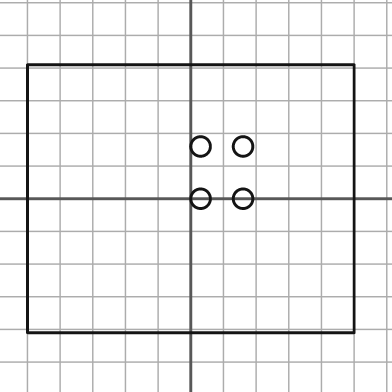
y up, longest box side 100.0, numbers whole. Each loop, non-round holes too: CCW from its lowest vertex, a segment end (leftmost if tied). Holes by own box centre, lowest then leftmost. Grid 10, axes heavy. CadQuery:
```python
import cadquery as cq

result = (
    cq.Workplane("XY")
    .moveTo(-50.0, -41.0)
    .lineTo(50.0, -41.0)
    .lineTo(50.0, 41.0)
    .lineTo(-50.0, 41.0)
    .close()
    .moveTo(3.0, 0.0)
    .circle(3.0)
    .moveTo(16.0, 0.0)
    .circle(3.0)
    .moveTo(3.0, 16.0)
    .circle(3.0)
    .moveTo(16.0, 16.0)
    .circle(3.0)
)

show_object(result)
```